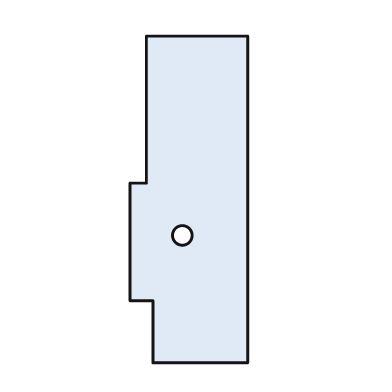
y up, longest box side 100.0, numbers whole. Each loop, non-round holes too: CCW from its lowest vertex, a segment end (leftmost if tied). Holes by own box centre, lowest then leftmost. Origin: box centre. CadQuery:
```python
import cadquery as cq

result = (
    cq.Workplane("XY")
    .moveTo(-11.0, -50.0)
    .lineTo(18.0, -50.0)
    .lineTo(18.0, 50.0)
    .lineTo(-13.0, 50.0)
    .lineTo(-13.0, 5.0)
    .lineTo(-18.0, 5.0)
    .lineTo(-18.0, -31.0)
    .lineTo(-11.0, -31.0)
    .close()
    .moveTo(-2.0, -11.0)
    .circle(3.0)
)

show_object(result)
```